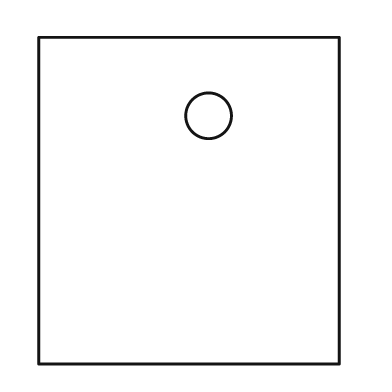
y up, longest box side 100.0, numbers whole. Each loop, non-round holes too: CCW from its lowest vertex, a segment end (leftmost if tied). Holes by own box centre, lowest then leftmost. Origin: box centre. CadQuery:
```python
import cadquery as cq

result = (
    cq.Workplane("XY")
    .moveTo(-46.0, -50.0)
    .lineTo(46.0, -50.0)
    .lineTo(46.0, 50.0)
    .lineTo(-46.0, 50.0)
    .close()
    .moveTo(6.0, 26.0)
    .circle(7.0)
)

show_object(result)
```